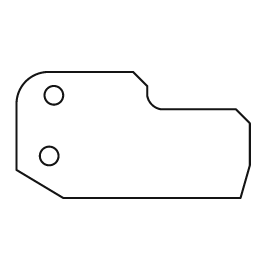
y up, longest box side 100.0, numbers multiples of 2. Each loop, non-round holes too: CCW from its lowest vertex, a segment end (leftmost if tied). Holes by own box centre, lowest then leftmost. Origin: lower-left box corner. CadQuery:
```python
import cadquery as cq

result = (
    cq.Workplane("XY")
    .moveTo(20.0, 0.0)
    .lineTo(96.0, 0.0)
    .lineTo(100.0, 14.0)
    .lineTo(100.0, 32.0)
    .lineTo(94.0, 38.0)
    .lineTo(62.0, 38.0)
    .threePointArc((58.0, 40.0), (56.0, 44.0))
    .lineTo(56.0, 48.0)
    .lineTo(50.0, 54.0)
    .lineTo(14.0, 54.0)
    .threePointArc((4.0, 50.0), (0.0, 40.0))
    .lineTo(0.0, 12.0)
    .close()
    .moveTo(14.0, 18.0)
    .circle(4.0)
    .moveTo(16.0, 44.0)
    .circle(4.0)
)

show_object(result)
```